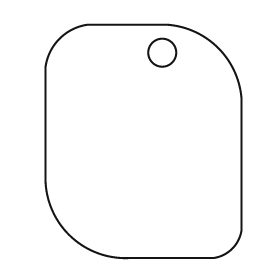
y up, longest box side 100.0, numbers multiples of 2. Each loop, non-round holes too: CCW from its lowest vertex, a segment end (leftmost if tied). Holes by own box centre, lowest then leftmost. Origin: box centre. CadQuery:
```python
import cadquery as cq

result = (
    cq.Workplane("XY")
    .moveTo(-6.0, -50.0)
    .lineTo(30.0, -50.0)
    .threePointArc((38.0, -46.0), (42.0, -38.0))
    .lineTo(42.0, 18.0)
    .threePointArc((32.0, 40.0), (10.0, 50.0))
    .lineTo(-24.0, 50.0)
    .threePointArc((-36.0, 44.0), (-42.0, 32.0))
    .lineTo(-42.0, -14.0)
    .threePointArc((-32.0, -40.0), (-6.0, -50.0))
    .close()
    .moveTo(8.0, 38.0)
    .circle(6.0)
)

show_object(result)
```